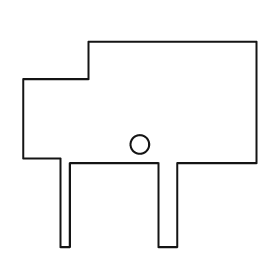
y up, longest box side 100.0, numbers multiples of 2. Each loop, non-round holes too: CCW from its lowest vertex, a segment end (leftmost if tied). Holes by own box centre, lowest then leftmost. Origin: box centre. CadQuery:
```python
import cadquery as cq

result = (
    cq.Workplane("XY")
    .moveTo(-34.0, -44.0)
    .lineTo(-30.0, -44.0)
    .lineTo(-30.0, -8.0)
    .lineTo(8.0, -8.0)
    .lineTo(8.0, -44.0)
    .lineTo(16.0, -44.0)
    .lineTo(16.0, -8.0)
    .lineTo(50.0, -8.0)
    .lineTo(50.0, 44.0)
    .lineTo(-22.0, 44.0)
    .lineTo(-22.0, 28.0)
    .lineTo(-50.0, 28.0)
    .lineTo(-50.0, -6.0)
    .lineTo(-34.0, -6.0)
    .close()
    .moveTo(0.0, 0.0)
    .circle(4.0)
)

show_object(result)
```